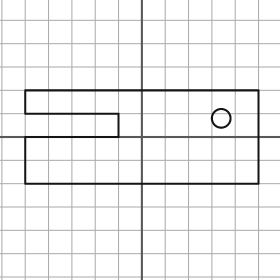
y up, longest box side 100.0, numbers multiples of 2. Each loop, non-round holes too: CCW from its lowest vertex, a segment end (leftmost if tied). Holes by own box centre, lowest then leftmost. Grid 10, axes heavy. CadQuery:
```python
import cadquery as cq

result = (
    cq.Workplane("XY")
    .moveTo(-50.0, -20.0)
    .lineTo(50.0, -20.0)
    .lineTo(50.0, 20.0)
    .lineTo(-50.0, 20.0)
    .lineTo(-50.0, 10.0)
    .lineTo(-10.0, 10.0)
    .lineTo(-10.0, 0.0)
    .lineTo(-50.0, 0.0)
    .close()
    .moveTo(34.0, 8.0)
    .circle(4.0)
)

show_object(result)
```